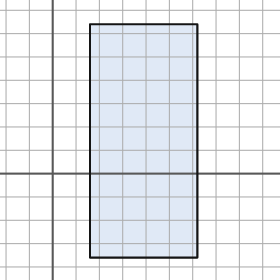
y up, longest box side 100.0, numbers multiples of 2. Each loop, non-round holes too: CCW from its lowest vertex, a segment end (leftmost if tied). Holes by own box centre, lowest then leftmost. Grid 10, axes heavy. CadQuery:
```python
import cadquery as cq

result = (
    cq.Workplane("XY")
    .moveTo(16.0, -36.0)
    .lineTo(62.0, -36.0)
    .lineTo(62.0, 64.0)
    .lineTo(16.0, 64.0)
    .close()
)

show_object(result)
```